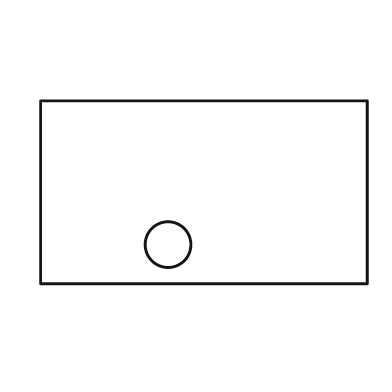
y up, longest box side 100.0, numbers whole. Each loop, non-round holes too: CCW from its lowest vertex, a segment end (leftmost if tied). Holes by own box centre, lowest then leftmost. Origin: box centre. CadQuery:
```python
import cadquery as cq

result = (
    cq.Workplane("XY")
    .moveTo(-50.0, -28.0)
    .lineTo(50.0, -28.0)
    .lineTo(50.0, 28.0)
    .lineTo(-50.0, 28.0)
    .close()
    .moveTo(-11.0, -16.0)
    .circle(7.0)
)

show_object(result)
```